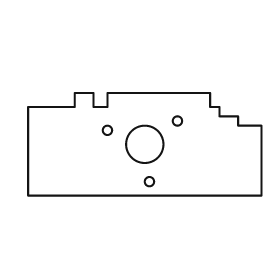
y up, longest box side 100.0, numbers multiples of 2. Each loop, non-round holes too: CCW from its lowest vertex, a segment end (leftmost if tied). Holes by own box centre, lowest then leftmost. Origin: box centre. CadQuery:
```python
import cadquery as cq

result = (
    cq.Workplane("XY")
    .moveTo(-50.0, -22.0)
    .lineTo(50.0, -22.0)
    .lineTo(50.0, 8.0)
    .lineTo(40.0, 8.0)
    .lineTo(40.0, 12.0)
    .lineTo(32.0, 12.0)
    .lineTo(32.0, 16.0)
    .lineTo(28.0, 16.0)
    .lineTo(28.0, 22.0)
    .lineTo(-16.0, 22.0)
    .lineTo(-16.0, 16.0)
    .lineTo(-22.0, 16.0)
    .lineTo(-22.0, 22.0)
    .lineTo(-30.0, 22.0)
    .lineTo(-30.0, 16.0)
    .lineTo(-50.0, 16.0)
    .close()
    .moveTo(2.0, -16.0)
    .circle(2.0)
    .moveTo(0.0, 0.0)
    .circle(8.0)
    .moveTo(-16.0, 6.0)
    .circle(2.0)
    .moveTo(14.0, 10.0)
    .circle(2.0)
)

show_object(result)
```